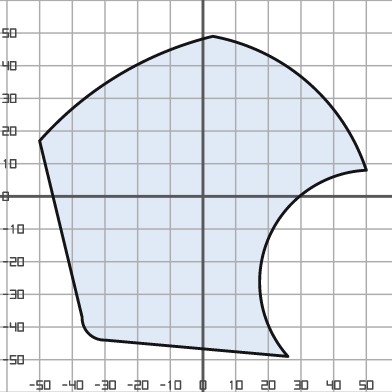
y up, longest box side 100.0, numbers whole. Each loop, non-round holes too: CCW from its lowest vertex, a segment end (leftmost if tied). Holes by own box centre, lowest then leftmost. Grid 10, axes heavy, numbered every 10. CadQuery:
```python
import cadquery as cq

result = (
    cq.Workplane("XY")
    .moveTo(26.0, -49.0)
    .threePointArc((20.0, -13.0), (50.0, 8.0))
    .threePointArc((32.0, 35.0), (3.0, 49.0))
    .threePointArc((-26.0, 37.0), (-50.0, 17.0))
    .lineTo(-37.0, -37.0)
    .threePointArc((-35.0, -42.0), (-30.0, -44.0))
    .close()
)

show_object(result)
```